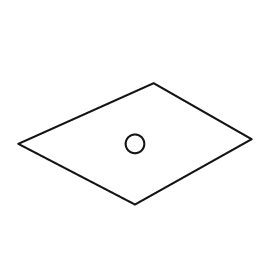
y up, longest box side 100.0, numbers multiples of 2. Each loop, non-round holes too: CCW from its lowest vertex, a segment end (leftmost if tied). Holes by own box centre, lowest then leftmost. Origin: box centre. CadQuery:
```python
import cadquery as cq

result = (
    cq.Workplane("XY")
    .moveTo(0.0, -26.0)
    .lineTo(50.0, 2.0)
    .lineTo(8.0, 26.0)
    .lineTo(-50.0, 0.0)
    .close()
    .moveTo(0.0, 0.0)
    .circle(4.0)
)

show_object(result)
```